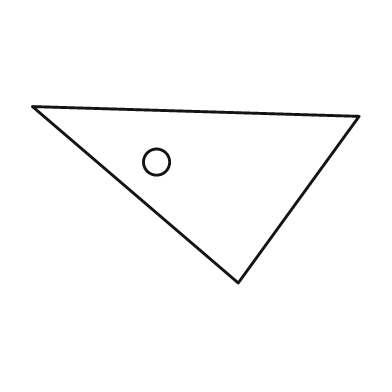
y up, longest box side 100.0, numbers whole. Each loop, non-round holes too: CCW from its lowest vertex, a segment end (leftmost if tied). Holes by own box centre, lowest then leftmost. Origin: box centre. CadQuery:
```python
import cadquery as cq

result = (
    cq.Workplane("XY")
    .moveTo(13.0, -27.0)
    .lineTo(50.0, 24.0)
    .lineTo(-50.0, 27.0)
    .close()
    .moveTo(-12.0, 10.0)
    .circle(4.0)
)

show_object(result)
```